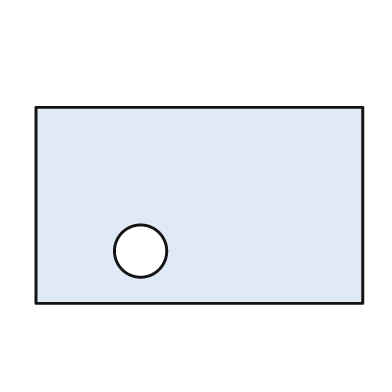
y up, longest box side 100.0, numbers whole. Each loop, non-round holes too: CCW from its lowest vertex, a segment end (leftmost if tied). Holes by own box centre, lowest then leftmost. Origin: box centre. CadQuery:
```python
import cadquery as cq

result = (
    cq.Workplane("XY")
    .moveTo(-50.0, -30.0)
    .lineTo(50.0, -30.0)
    .lineTo(50.0, 30.0)
    .lineTo(-50.0, 30.0)
    .close()
    .moveTo(-18.0, -14.0)
    .circle(8.0)
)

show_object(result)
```